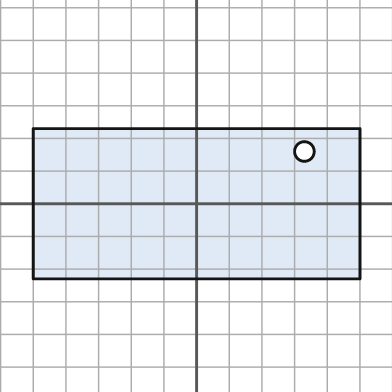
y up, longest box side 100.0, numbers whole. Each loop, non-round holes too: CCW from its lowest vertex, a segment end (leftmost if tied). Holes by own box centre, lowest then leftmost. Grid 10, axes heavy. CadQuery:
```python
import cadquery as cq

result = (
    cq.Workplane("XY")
    .moveTo(-50.0, -23.0)
    .lineTo(50.0, -23.0)
    .lineTo(50.0, 23.0)
    .lineTo(-50.0, 23.0)
    .close()
    .moveTo(33.0, 16.0)
    .circle(3.0)
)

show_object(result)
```